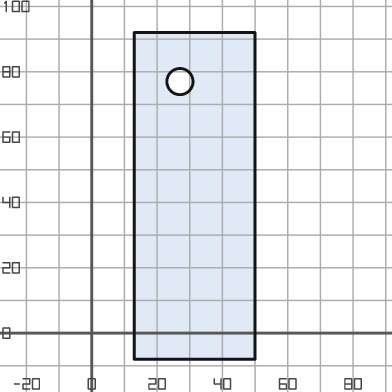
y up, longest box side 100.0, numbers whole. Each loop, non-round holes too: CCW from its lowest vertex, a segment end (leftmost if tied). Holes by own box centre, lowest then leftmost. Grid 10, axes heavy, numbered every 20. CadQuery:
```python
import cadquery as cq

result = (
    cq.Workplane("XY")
    .moveTo(13.0, -8.0)
    .lineTo(50.0, -8.0)
    .lineTo(50.0, 92.0)
    .lineTo(13.0, 92.0)
    .close()
    .moveTo(27.0, 77.0)
    .circle(4.0)
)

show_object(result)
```